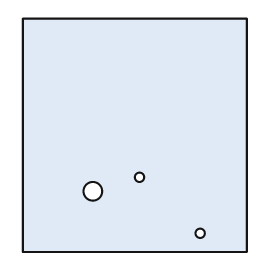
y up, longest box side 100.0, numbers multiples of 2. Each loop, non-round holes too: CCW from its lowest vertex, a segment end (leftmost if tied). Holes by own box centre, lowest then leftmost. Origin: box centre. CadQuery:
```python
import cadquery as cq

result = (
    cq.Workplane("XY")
    .moveTo(-48.0, -50.0)
    .lineTo(48.0, -50.0)
    .lineTo(48.0, 50.0)
    .lineTo(-48.0, 50.0)
    .close()
    .moveTo(28.0, -42.0)
    .circle(2.0)
    .moveTo(-18.0, -24.0)
    .circle(4.0)
    .moveTo(2.0, -18.0)
    .circle(2.0)
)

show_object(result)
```